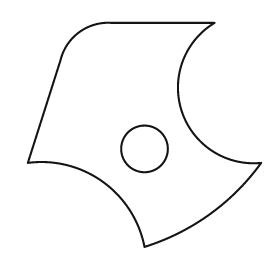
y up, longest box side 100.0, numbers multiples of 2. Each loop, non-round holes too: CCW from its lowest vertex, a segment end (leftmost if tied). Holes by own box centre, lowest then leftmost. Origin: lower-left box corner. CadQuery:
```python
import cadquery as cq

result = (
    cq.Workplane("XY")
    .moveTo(50.0, 0.0)
    .threePointArc((78.0, 14.0), (100.0, 36.0))
    .threePointArc((66.0, 58.0), (80.0, 96.0))
    .lineTo(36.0, 96.0)
    .threePointArc((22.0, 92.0), (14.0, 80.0))
    .lineTo(0.0, 36.0)
    .threePointArc((32.0, 28.0), (50.0, 0.0))
    .close()
    .moveTo(50.0, 42.0)
    .circle(10.0)
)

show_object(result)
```